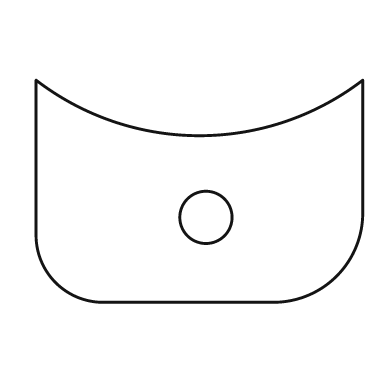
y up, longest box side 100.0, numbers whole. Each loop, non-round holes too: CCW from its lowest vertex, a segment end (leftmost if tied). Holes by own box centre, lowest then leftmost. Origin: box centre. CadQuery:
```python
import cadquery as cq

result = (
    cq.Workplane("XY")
    .moveTo(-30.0, -34.0)
    .lineTo(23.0, -34.0)
    .threePointArc((42.0, -26.0), (50.0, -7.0))
    .lineTo(50.0, 34.0)
    .threePointArc((0.0, 17.0), (-50.0, 34.0))
    .lineTo(-50.0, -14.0)
    .threePointArc((-44.0, -28.0), (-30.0, -34.0))
    .close()
    .moveTo(2.0, -8.0)
    .circle(8.0)
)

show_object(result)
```